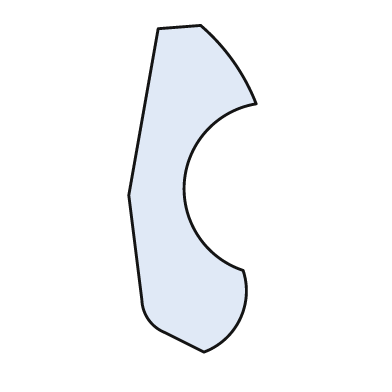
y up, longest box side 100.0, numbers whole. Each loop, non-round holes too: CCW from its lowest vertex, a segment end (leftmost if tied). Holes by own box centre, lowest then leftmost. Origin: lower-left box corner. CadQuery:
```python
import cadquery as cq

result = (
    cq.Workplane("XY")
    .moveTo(23.0, 0.0)
    .threePointArc((34.0, 10.0), (35.0, 25.0))
    .threePointArc((17.0, 52.0), (39.0, 76.0))
    .threePointArc((32.0, 89.0), (22.0, 100.0))
    .lineTo(9.0, 99.0)
    .lineTo(0.0, 48.0)
    .lineTo(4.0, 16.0)
    .threePointArc((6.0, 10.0), (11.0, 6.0))
    .close()
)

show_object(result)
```